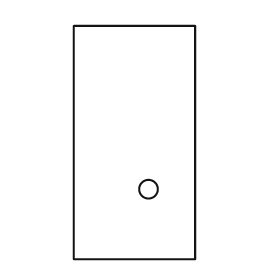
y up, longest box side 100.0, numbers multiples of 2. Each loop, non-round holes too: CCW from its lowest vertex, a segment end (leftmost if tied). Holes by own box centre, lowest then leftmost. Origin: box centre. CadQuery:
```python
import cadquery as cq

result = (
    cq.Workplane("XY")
    .moveTo(-26.0, -50.0)
    .lineTo(26.0, -50.0)
    .lineTo(26.0, 50.0)
    .lineTo(-26.0, 50.0)
    .close()
    .moveTo(6.0, -20.0)
    .circle(4.0)
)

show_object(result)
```